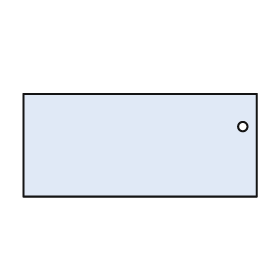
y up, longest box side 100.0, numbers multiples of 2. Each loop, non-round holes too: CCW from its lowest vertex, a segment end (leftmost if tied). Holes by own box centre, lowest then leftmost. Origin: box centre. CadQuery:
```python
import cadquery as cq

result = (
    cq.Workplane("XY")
    .moveTo(-50.0, -22.0)
    .lineTo(50.0, -22.0)
    .lineTo(50.0, 22.0)
    .lineTo(-50.0, 22.0)
    .close()
    .moveTo(44.0, 8.0)
    .circle(2.0)
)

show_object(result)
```